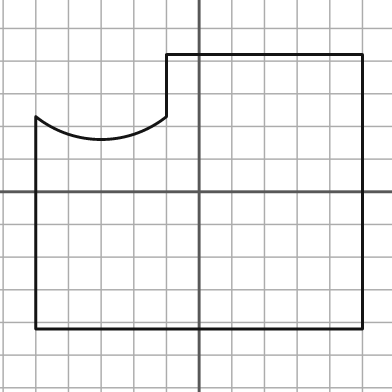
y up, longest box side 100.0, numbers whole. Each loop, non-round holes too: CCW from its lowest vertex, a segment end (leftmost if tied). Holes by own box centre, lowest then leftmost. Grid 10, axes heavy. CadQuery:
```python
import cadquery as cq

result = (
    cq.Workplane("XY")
    .moveTo(-50.0, -42.0)
    .lineTo(50.0, -42.0)
    .lineTo(50.0, 42.0)
    .lineTo(-10.0, 42.0)
    .lineTo(-10.0, 23.0)
    .threePointArc((-30.0, 16.0), (-50.0, 23.0))
    .close()
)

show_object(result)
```